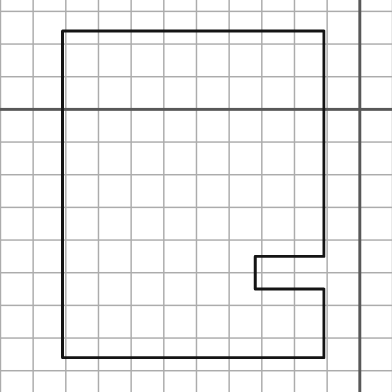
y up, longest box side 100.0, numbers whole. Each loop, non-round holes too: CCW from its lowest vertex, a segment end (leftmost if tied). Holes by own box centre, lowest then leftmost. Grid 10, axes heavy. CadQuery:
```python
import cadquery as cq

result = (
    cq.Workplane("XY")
    .moveTo(-91.0, -76.0)
    .lineTo(-11.0, -76.0)
    .lineTo(-11.0, -55.0)
    .lineTo(-32.0, -55.0)
    .lineTo(-32.0, -45.0)
    .lineTo(-11.0, -45.0)
    .lineTo(-11.0, 24.0)
    .lineTo(-91.0, 24.0)
    .close()
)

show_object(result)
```